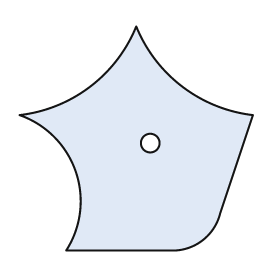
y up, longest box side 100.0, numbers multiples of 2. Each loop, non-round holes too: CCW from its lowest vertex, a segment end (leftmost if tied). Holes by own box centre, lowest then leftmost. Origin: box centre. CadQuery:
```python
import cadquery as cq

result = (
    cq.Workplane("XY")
    .moveTo(-30.0, -48.0)
    .lineTo(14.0, -48.0)
    .threePointArc((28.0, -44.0), (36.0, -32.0))
    .lineTo(50.0, 10.0)
    .threePointArc((20.0, 22.0), (0.0, 48.0))
    .threePointArc((-20.0, 22.0), (-50.0, 10.0))
    .threePointArc((-26.0, -14.0), (-30.0, -48.0))
    .close()
    .moveTo(6.0, -2.0)
    .circle(4.0)
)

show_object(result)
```